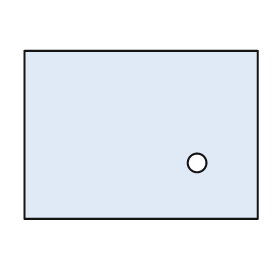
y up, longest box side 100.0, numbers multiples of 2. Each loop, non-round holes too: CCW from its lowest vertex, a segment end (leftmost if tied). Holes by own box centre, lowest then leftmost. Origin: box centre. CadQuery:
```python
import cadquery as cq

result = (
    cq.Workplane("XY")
    .moveTo(-50.0, -36.0)
    .lineTo(50.0, -36.0)
    .lineTo(50.0, 36.0)
    .lineTo(-50.0, 36.0)
    .close()
    .moveTo(24.0, -12.0)
    .circle(4.0)
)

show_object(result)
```